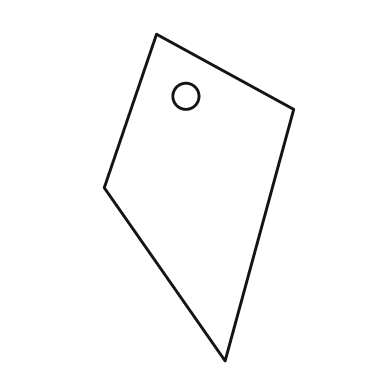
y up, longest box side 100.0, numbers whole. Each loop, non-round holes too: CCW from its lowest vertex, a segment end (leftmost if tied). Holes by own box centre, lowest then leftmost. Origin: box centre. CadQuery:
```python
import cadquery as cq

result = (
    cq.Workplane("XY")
    .moveTo(8.0, -50.0)
    .lineTo(29.0, 27.0)
    .lineTo(-13.0, 50.0)
    .lineTo(-29.0, 3.0)
    .close()
    .moveTo(-4.0, 31.0)
    .circle(4.0)
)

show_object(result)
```